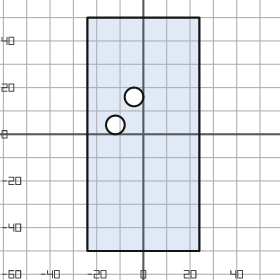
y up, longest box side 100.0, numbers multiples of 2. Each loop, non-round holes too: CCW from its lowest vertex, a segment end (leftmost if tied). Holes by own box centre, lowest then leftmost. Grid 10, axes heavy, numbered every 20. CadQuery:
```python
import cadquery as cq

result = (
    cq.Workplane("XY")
    .moveTo(-24.0, -50.0)
    .lineTo(24.0, -50.0)
    .lineTo(24.0, 50.0)
    .lineTo(-24.0, 50.0)
    .close()
    .moveTo(-12.0, 4.0)
    .circle(4.0)
    .moveTo(-4.0, 16.0)
    .circle(4.0)
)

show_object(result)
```